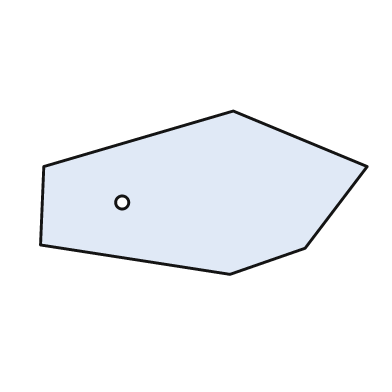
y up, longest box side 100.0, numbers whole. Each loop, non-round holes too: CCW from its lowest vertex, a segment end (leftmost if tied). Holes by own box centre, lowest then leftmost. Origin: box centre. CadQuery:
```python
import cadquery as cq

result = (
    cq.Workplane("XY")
    .moveTo(8.0, -25.0)
    .lineTo(31.0, -17.0)
    .lineTo(50.0, 8.0)
    .lineTo(9.0, 25.0)
    .lineTo(-49.0, 8.0)
    .lineTo(-50.0, -16.0)
    .close()
    .moveTo(-25.0, -3.0)
    .circle(2.0)
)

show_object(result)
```